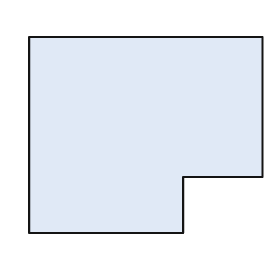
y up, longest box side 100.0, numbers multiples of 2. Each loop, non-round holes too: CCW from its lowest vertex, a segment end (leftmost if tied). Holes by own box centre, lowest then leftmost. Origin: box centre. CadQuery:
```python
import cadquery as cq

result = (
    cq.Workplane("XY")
    .moveTo(-50.0, -42.0)
    .lineTo(16.0, -42.0)
    .lineTo(16.0, -18.0)
    .lineTo(50.0, -18.0)
    .lineTo(50.0, 42.0)
    .lineTo(-50.0, 42.0)
    .close()
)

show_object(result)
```